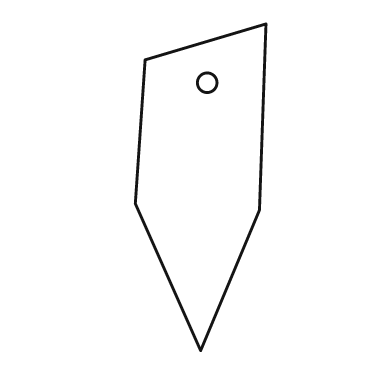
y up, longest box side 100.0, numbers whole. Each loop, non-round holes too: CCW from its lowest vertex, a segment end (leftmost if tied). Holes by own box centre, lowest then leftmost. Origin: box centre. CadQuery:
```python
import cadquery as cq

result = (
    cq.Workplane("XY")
    .moveTo(0.0, -50.0)
    .lineTo(18.0, -7.0)
    .lineTo(20.0, 50.0)
    .lineTo(-17.0, 39.0)
    .lineTo(-20.0, -5.0)
    .close()
    .moveTo(2.0, 32.0)
    .circle(3.0)
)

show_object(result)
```